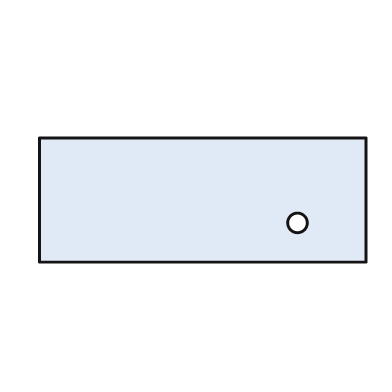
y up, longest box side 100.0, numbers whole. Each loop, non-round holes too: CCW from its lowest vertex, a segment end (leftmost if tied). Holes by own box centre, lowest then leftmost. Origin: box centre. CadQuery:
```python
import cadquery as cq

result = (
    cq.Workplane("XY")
    .moveTo(-50.0, -19.0)
    .lineTo(50.0, -19.0)
    .lineTo(50.0, 19.0)
    .lineTo(-50.0, 19.0)
    .close()
    .moveTo(29.0, -7.0)
    .circle(3.0)
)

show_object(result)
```